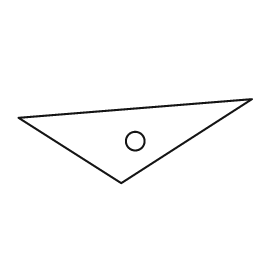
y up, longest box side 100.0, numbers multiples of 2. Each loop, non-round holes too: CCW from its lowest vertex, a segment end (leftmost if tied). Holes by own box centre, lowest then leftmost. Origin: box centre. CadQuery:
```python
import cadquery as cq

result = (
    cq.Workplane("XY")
    .moveTo(-6.0, -18.0)
    .lineTo(50.0, 18.0)
    .lineTo(-50.0, 10.0)
    .close()
    .moveTo(0.0, 0.0)
    .circle(4.0)
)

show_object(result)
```